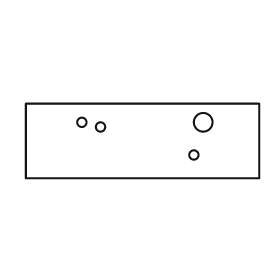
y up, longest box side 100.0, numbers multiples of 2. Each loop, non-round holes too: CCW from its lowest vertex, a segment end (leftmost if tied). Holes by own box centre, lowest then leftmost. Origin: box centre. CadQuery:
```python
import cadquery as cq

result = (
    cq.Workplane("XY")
    .moveTo(-50.0, -16.0)
    .lineTo(50.0, -16.0)
    .lineTo(50.0, 16.0)
    .lineTo(-50.0, 16.0)
    .close()
    .moveTo(22.0, -6.0)
    .circle(2.0)
    .moveTo(-18.0, 6.0)
    .circle(2.0)
    .moveTo(-26.0, 8.0)
    .circle(2.0)
    .moveTo(26.0, 8.0)
    .circle(4.0)
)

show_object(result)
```